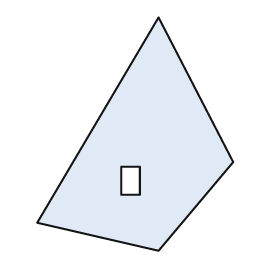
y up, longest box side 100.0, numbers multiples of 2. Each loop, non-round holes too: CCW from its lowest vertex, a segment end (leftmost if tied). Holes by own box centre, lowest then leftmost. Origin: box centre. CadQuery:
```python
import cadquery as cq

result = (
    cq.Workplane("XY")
    .moveTo(10.0, -50.0)
    .lineTo(42.0, -12.0)
    .lineTo(10.0, 50.0)
    .lineTo(-42.0, -38.0)
    .close()
    .moveTo(-6.0, -26.0)
    .lineTo(2.0, -26.0)
    .lineTo(2.0, -14.0)
    .lineTo(-6.0, -14.0)
    .close()
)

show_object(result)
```